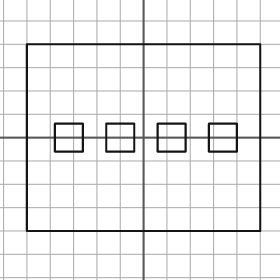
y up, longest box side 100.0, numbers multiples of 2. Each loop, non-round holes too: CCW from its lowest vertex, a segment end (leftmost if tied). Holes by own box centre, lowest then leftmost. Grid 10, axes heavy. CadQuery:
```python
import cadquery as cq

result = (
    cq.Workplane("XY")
    .moveTo(-50.0, -40.0)
    .lineTo(50.0, -40.0)
    .lineTo(50.0, 40.0)
    .lineTo(-50.0, 40.0)
    .close()
    .moveTo(-38.0, -6.0)
    .lineTo(-26.0, -6.0)
    .lineTo(-26.0, 6.0)
    .lineTo(-38.0, 6.0)
    .close()
    .moveTo(-16.0, -6.0)
    .lineTo(-4.0, -6.0)
    .lineTo(-4.0, 6.0)
    .lineTo(-16.0, 6.0)
    .close()
    .moveTo(6.0, -6.0)
    .lineTo(18.0, -6.0)
    .lineTo(18.0, 6.0)
    .lineTo(6.0, 6.0)
    .close()
    .moveTo(28.0, -6.0)
    .lineTo(40.0, -6.0)
    .lineTo(40.0, 6.0)
    .lineTo(28.0, 6.0)
    .close()
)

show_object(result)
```